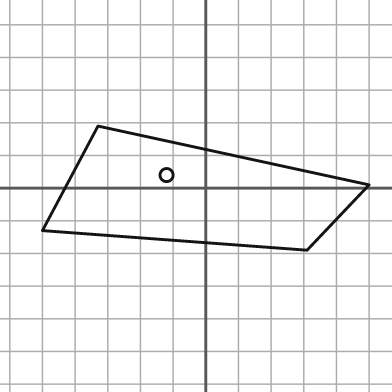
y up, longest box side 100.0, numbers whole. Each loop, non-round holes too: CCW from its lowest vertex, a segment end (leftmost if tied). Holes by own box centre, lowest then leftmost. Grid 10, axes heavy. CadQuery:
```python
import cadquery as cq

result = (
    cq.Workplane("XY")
    .moveTo(31.0, -19.0)
    .lineTo(50.0, 1.0)
    .lineTo(-33.0, 19.0)
    .lineTo(-50.0, -13.0)
    .close()
    .moveTo(-12.0, 4.0)
    .circle(2.0)
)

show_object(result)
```